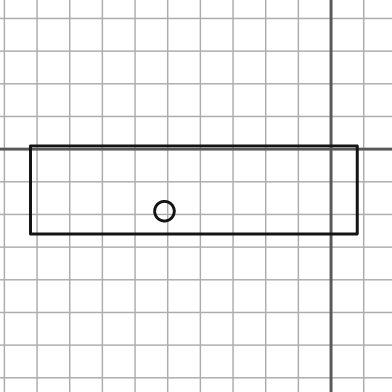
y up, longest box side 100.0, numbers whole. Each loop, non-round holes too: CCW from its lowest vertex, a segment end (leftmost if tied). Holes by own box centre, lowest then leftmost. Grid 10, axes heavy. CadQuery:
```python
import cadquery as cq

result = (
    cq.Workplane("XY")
    .moveTo(-92.0, -26.0)
    .lineTo(8.0, -26.0)
    .lineTo(8.0, 1.0)
    .lineTo(-92.0, 1.0)
    .close()
    .moveTo(-51.0, -19.0)
    .circle(3.0)
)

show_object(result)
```